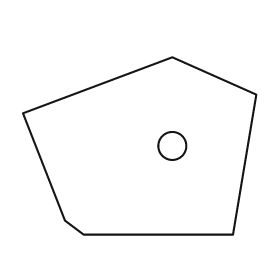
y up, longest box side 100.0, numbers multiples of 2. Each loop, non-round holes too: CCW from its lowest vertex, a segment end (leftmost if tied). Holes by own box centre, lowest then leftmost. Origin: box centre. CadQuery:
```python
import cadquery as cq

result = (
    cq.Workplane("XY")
    .moveTo(-24.0, -38.0)
    .lineTo(40.0, -38.0)
    .lineTo(50.0, 22.0)
    .lineTo(14.0, 38.0)
    .lineTo(-50.0, 14.0)
    .lineTo(-32.0, -32.0)
    .close()
    .moveTo(14.0, 0.0)
    .circle(6.0)
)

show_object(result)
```